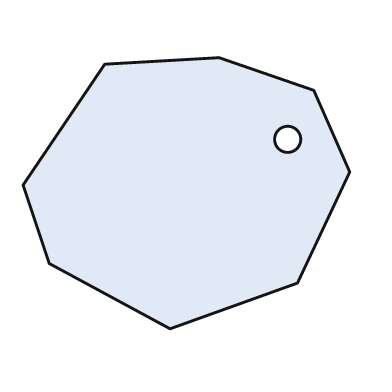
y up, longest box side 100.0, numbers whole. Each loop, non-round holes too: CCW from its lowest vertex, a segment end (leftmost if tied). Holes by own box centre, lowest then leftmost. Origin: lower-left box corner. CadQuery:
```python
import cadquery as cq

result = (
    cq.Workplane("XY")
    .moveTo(45.0, 0.0)
    .lineTo(84.0, 14.0)
    .lineTo(100.0, 48.0)
    .lineTo(89.0, 73.0)
    .lineTo(60.0, 83.0)
    .lineTo(25.0, 81.0)
    .lineTo(0.0, 44.0)
    .lineTo(8.0, 20.0)
    .close()
    .moveTo(81.0, 58.0)
    .circle(4.0)
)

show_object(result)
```